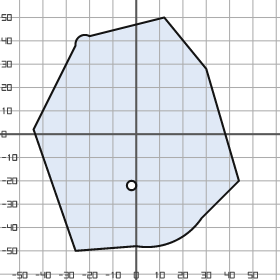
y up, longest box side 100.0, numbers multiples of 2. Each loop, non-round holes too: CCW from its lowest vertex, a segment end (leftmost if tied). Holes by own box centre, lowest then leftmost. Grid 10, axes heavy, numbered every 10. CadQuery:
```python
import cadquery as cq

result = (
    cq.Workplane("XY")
    .moveTo(-26.0, -50.0)
    .lineTo(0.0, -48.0)
    .threePointArc((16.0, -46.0), (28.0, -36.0))
    .lineTo(44.0, -20.0)
    .lineTo(30.0, 28.0)
    .lineTo(12.0, 50.0)
    .lineTo(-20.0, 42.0)
    .threePointArc((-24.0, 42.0), (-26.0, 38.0))
    .lineTo(-44.0, 2.0)
    .close()
    .moveTo(-2.0, -22.0)
    .circle(2.0)
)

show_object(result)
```